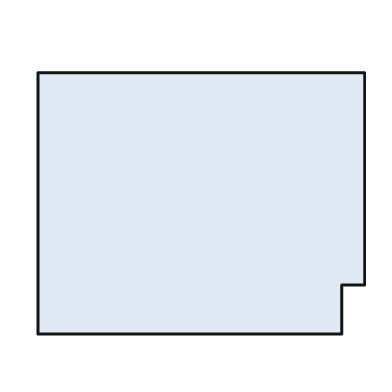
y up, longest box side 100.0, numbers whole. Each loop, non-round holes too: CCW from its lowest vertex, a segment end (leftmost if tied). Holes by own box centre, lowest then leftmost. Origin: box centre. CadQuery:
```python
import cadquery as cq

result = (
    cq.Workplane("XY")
    .moveTo(-50.0, -40.0)
    .lineTo(43.0, -40.0)
    .lineTo(43.0, -25.0)
    .lineTo(50.0, -25.0)
    .lineTo(50.0, 40.0)
    .lineTo(-50.0, 40.0)
    .close()
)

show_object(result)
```